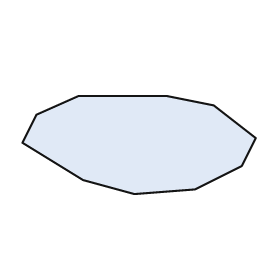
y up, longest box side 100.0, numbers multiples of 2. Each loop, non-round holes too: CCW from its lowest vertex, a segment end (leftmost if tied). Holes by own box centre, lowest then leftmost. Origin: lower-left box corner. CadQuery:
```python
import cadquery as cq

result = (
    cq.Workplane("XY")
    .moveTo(48.0, 0.0)
    .lineTo(74.0, 2.0)
    .lineTo(94.0, 12.0)
    .lineTo(100.0, 24.0)
    .lineTo(82.0, 38.0)
    .lineTo(62.0, 42.0)
    .lineTo(24.0, 42.0)
    .lineTo(6.0, 34.0)
    .lineTo(0.0, 22.0)
    .lineTo(26.0, 6.0)
    .close()
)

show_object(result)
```